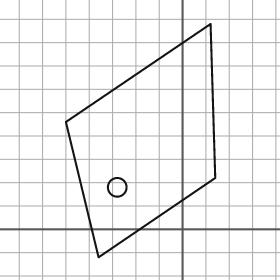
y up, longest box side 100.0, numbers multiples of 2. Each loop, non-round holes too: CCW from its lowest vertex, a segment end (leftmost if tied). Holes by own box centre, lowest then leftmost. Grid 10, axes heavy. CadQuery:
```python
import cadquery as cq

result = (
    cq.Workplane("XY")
    .moveTo(-36.0, -12.0)
    .lineTo(14.0, 22.0)
    .lineTo(12.0, 88.0)
    .lineTo(-50.0, 46.0)
    .close()
    .moveTo(-28.0, 18.0)
    .circle(4.0)
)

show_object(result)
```